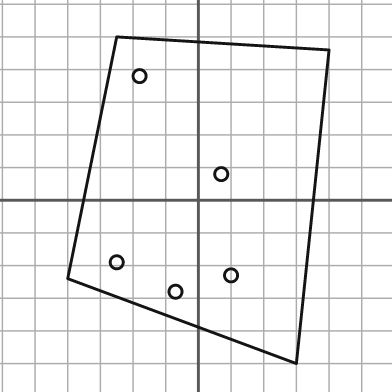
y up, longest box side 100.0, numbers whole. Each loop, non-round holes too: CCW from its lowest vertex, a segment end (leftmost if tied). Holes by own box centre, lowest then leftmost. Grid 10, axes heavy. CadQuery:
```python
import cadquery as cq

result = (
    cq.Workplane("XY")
    .moveTo(30.0, -50.0)
    .lineTo(40.0, 46.0)
    .lineTo(-25.0, 50.0)
    .lineTo(-40.0, -24.0)
    .close()
    .moveTo(-7.0, -28.0)
    .circle(2.0)
    .moveTo(10.0, -23.0)
    .circle(2.0)
    .moveTo(-25.0, -19.0)
    .circle(2.0)
    .moveTo(7.0, 8.0)
    .circle(2.0)
    .moveTo(-18.0, 38.0)
    .circle(2.0)
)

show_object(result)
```